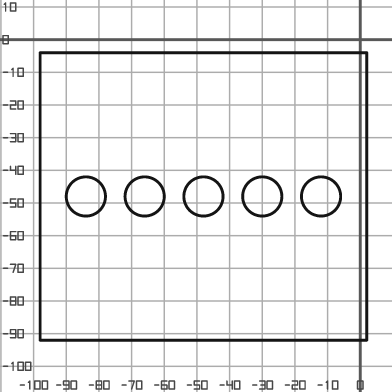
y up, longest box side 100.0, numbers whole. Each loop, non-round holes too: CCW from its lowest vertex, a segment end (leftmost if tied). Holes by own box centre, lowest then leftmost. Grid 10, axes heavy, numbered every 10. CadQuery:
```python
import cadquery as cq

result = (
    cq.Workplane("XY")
    .moveTo(-98.0, -92.0)
    .lineTo(2.0, -92.0)
    .lineTo(2.0, -4.0)
    .lineTo(-98.0, -4.0)
    .close()
    .moveTo(-84.0, -48.0)
    .circle(6.0)
    .moveTo(-66.0, -48.0)
    .circle(6.0)
    .moveTo(-48.0, -48.0)
    .circle(6.0)
    .moveTo(-30.0, -48.0)
    .circle(6.0)
    .moveTo(-12.0, -48.0)
    .circle(6.0)
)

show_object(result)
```